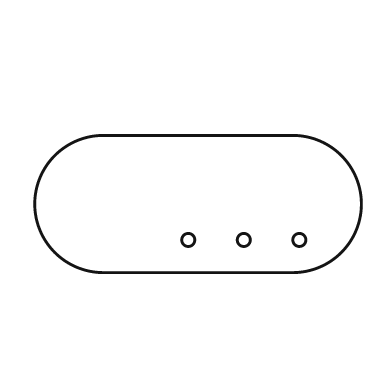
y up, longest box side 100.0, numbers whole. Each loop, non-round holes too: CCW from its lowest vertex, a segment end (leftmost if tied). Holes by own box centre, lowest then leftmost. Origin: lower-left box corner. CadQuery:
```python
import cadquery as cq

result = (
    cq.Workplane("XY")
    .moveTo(21.0, 0.0)
    .lineTo(79.0, 0.0)
    .threePointArc((100.0, 21.0), (79.0, 42.0))
    .lineTo(21.0, 42.0)
    .threePointArc((0.0, 21.0), (21.0, 0.0))
    .close()
    .moveTo(47.0, 10.0)
    .circle(2.0)
    .moveTo(64.0, 10.0)
    .circle(2.0)
    .moveTo(81.0, 10.0)
    .circle(2.0)
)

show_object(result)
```